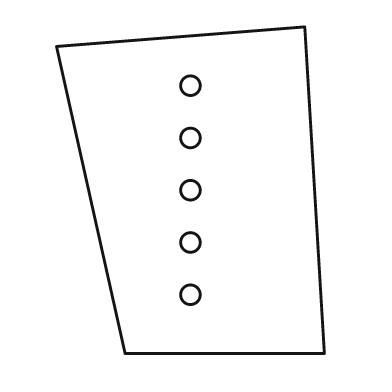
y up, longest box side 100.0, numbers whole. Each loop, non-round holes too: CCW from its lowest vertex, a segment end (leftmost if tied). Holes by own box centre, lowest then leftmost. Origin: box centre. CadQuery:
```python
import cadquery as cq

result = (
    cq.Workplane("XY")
    .moveTo(-20.0, -50.0)
    .lineTo(41.0, -50.0)
    .lineTo(35.0, 50.0)
    .lineTo(-41.0, 44.0)
    .close()
    .moveTo(0.0, -32.0)
    .circle(3.0)
    .moveTo(0.0, -16.0)
    .circle(3.0)
    .moveTo(0.0, 0.0)
    .circle(3.0)
    .moveTo(0.0, 16.0)
    .circle(3.0)
    .moveTo(0.0, 32.0)
    .circle(3.0)
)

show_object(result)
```